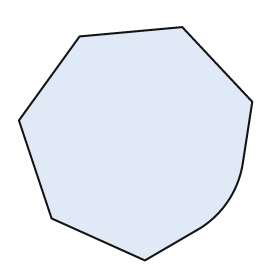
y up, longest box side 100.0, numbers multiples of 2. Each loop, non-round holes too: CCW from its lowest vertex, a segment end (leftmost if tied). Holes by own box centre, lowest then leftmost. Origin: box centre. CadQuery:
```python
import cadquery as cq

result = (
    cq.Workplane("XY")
    .moveTo(4.0, -50.0)
    .lineTo(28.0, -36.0)
    .threePointArc((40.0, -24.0), (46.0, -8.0))
    .lineTo(50.0, 18.0)
    .lineTo(20.0, 50.0)
    .lineTo(-24.0, 46.0)
    .lineTo(-50.0, 10.0)
    .lineTo(-36.0, -32.0)
    .close()
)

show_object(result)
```